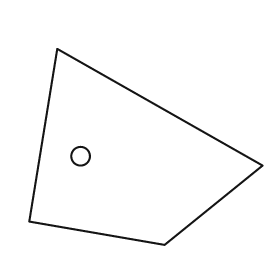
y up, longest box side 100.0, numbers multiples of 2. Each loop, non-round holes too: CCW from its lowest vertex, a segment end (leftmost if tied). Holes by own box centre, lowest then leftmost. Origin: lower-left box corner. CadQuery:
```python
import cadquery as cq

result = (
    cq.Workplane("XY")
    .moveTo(58.0, 0.0)
    .lineTo(100.0, 34.0)
    .lineTo(12.0, 84.0)
    .lineTo(0.0, 10.0)
    .close()
    .moveTo(22.0, 38.0)
    .circle(4.0)
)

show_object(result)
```